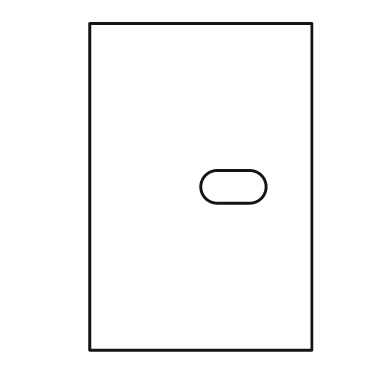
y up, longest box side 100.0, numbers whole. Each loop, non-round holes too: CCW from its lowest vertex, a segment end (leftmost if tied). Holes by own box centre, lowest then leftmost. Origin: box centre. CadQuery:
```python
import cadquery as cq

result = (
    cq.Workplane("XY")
    .moveTo(-34.0, -50.0)
    .lineTo(34.0, -50.0)
    .lineTo(34.0, 50.0)
    .lineTo(-34.0, 50.0)
    .close()
    .moveTo(5.0, -5.0)
    .lineTo(15.0, -5.0)
    .threePointArc((20.0, 0.0), (15.0, 5.0))
    .lineTo(5.0, 5.0)
    .threePointArc((0.0, 0.0), (5.0, -5.0))
    .close()
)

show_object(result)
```